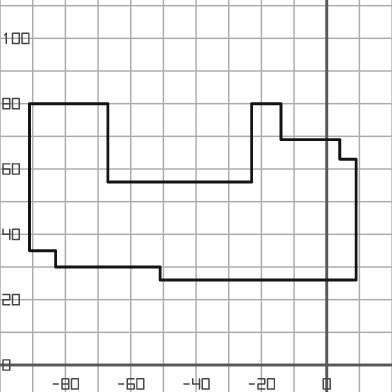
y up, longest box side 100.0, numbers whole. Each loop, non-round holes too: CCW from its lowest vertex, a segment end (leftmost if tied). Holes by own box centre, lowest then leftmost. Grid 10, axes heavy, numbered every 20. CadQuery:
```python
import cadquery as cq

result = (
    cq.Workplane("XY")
    .moveTo(-51.0, 26.0)
    .lineTo(9.0, 26.0)
    .lineTo(9.0, 63.0)
    .lineTo(4.0, 63.0)
    .lineTo(4.0, 69.0)
    .lineTo(-14.0, 69.0)
    .lineTo(-14.0, 80.0)
    .lineTo(-23.0, 80.0)
    .lineTo(-23.0, 56.0)
    .lineTo(-67.0, 56.0)
    .lineTo(-67.0, 80.0)
    .lineTo(-91.0, 80.0)
    .lineTo(-91.0, 35.0)
    .lineTo(-83.0, 35.0)
    .lineTo(-83.0, 30.0)
    .lineTo(-51.0, 30.0)
    .close()
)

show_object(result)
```